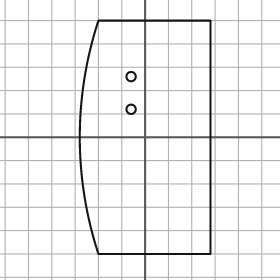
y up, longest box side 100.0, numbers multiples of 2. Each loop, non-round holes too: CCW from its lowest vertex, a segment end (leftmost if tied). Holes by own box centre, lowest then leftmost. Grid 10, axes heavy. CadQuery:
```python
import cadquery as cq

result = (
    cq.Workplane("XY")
    .moveTo(-20.0, -50.0)
    .lineTo(28.0, -50.0)
    .lineTo(28.0, 50.0)
    .lineTo(-20.0, 50.0)
    .threePointArc((-28.0, 0.0), (-20.0, -50.0))
    .close()
    .moveTo(-6.0, 12.0)
    .circle(2.0)
    .moveTo(-6.0, 26.0)
    .circle(2.0)
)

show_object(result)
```